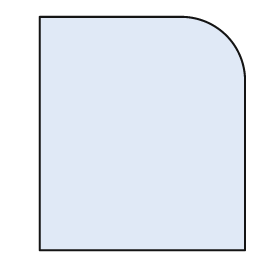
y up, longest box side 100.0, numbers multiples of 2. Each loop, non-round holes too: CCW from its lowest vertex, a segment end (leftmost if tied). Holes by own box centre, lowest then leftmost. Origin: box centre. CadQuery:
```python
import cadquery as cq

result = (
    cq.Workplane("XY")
    .moveTo(-44.0, -50.0)
    .lineTo(44.0, -50.0)
    .lineTo(44.0, 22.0)
    .threePointArc((36.0, 42.0), (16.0, 50.0))
    .lineTo(-44.0, 50.0)
    .close()
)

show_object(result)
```